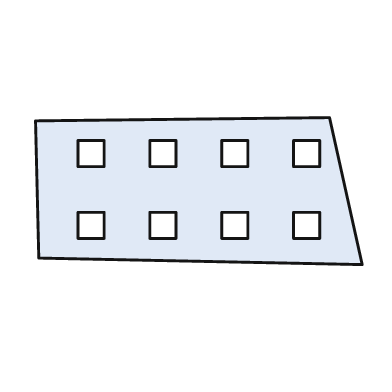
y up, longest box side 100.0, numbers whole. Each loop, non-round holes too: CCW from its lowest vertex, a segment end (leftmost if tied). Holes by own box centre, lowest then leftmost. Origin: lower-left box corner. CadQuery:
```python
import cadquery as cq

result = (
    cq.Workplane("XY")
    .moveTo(100.0, 0.0)
    .lineTo(90.0, 45.0)
    .lineTo(0.0, 44.0)
    .lineTo(1.0, 2.0)
    .close()
    .moveTo(13.0, 8.0)
    .lineTo(21.0, 8.0)
    .lineTo(21.0, 16.0)
    .lineTo(13.0, 16.0)
    .close()
    .moveTo(35.0, 8.0)
    .lineTo(43.0, 8.0)
    .lineTo(43.0, 16.0)
    .lineTo(35.0, 16.0)
    .close()
    .moveTo(57.0, 8.0)
    .lineTo(65.0, 8.0)
    .lineTo(65.0, 16.0)
    .lineTo(57.0, 16.0)
    .close()
    .moveTo(79.0, 8.0)
    .lineTo(87.0, 8.0)
    .lineTo(87.0, 16.0)
    .lineTo(79.0, 16.0)
    .close()
    .moveTo(13.0, 30.0)
    .lineTo(21.0, 30.0)
    .lineTo(21.0, 38.0)
    .lineTo(13.0, 38.0)
    .close()
    .moveTo(35.0, 30.0)
    .lineTo(43.0, 30.0)
    .lineTo(43.0, 38.0)
    .lineTo(35.0, 38.0)
    .close()
    .moveTo(57.0, 30.0)
    .lineTo(65.0, 30.0)
    .lineTo(65.0, 38.0)
    .lineTo(57.0, 38.0)
    .close()
    .moveTo(79.0, 30.0)
    .lineTo(87.0, 30.0)
    .lineTo(87.0, 38.0)
    .lineTo(79.0, 38.0)
    .close()
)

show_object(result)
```